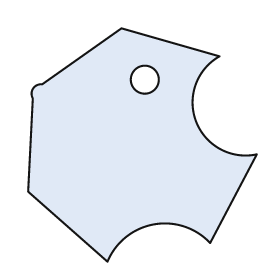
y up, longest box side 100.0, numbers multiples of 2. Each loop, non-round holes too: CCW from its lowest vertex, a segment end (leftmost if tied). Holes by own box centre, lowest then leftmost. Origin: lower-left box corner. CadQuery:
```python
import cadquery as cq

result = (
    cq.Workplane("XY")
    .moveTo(34.0, 0.0)
    .threePointArc((54.0, 16.0), (78.0, 8.0))
    .lineTo(98.0, 46.0)
    .threePointArc((72.0, 60.0), (82.0, 88.0))
    .lineTo(40.0, 100.0)
    .lineTo(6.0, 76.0)
    .threePointArc((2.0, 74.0), (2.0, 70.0))
    .lineTo(0.0, 30.0)
    .close()
    .moveTo(50.0, 78.0)
    .circle(6.0)
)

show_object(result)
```